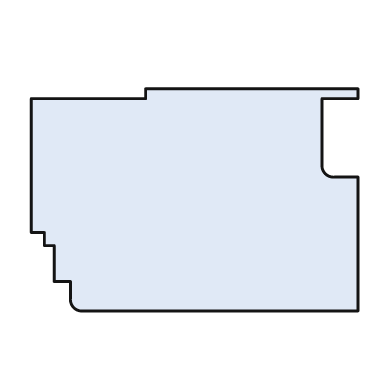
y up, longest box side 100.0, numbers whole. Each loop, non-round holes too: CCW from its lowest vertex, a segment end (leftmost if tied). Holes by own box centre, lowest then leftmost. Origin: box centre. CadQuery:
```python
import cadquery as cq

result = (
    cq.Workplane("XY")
    .moveTo(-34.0, -34.0)
    .lineTo(50.0, -34.0)
    .lineTo(50.0, 7.0)
    .lineTo(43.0, 7.0)
    .threePointArc((40.0, 8.0), (39.0, 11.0))
    .lineTo(39.0, 31.0)
    .lineTo(50.0, 31.0)
    .lineTo(50.0, 34.0)
    .lineTo(-15.0, 34.0)
    .lineTo(-15.0, 31.0)
    .lineTo(-50.0, 31.0)
    .lineTo(-50.0, -10.0)
    .lineTo(-46.0, -10.0)
    .lineTo(-46.0, -14.0)
    .lineTo(-43.0, -14.0)
    .lineTo(-43.0, -25.0)
    .lineTo(-38.0, -25.0)
    .lineTo(-38.0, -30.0)
    .threePointArc((-37.0, -33.0), (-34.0, -34.0))
    .close()
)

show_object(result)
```